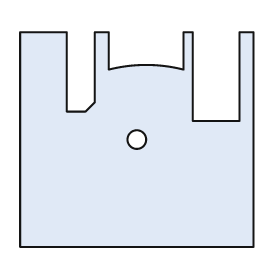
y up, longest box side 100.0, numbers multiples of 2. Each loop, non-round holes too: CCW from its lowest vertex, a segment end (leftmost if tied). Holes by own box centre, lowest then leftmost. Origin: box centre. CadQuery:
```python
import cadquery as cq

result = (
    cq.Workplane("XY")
    .moveTo(-50.0, -46.0)
    .lineTo(50.0, -46.0)
    .lineTo(50.0, 46.0)
    .lineTo(44.0, 46.0)
    .lineTo(44.0, 8.0)
    .lineTo(24.0, 8.0)
    .lineTo(24.0, 46.0)
    .lineTo(20.0, 46.0)
    .lineTo(20.0, 30.0)
    .threePointArc((4.0, 32.0), (-12.0, 30.0))
    .lineTo(-12.0, 46.0)
    .lineTo(-18.0, 46.0)
    .lineTo(-18.0, 16.0)
    .lineTo(-22.0, 12.0)
    .lineTo(-30.0, 12.0)
    .lineTo(-30.0, 46.0)
    .lineTo(-50.0, 46.0)
    .close()
    .moveTo(0.0, 0.0)
    .circle(4.0)
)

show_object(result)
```